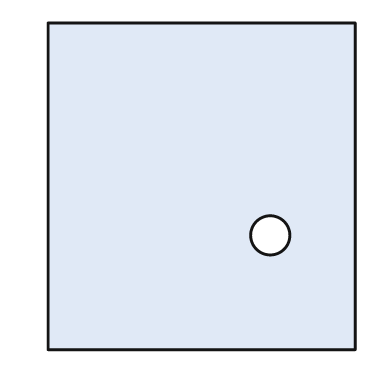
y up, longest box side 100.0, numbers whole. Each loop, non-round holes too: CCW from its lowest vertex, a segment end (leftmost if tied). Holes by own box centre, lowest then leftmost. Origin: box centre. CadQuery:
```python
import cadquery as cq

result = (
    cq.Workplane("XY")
    .moveTo(-47.0, -50.0)
    .lineTo(47.0, -50.0)
    .lineTo(47.0, 50.0)
    .lineTo(-47.0, 50.0)
    .close()
    .moveTo(21.0, -15.0)
    .circle(6.0)
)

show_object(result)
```